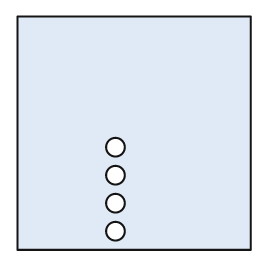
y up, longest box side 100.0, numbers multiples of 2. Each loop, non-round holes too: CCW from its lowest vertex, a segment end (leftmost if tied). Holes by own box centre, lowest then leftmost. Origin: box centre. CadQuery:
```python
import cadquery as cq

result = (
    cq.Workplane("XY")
    .moveTo(-50.0, -50.0)
    .lineTo(50.0, -50.0)
    .lineTo(50.0, 50.0)
    .lineTo(-50.0, 50.0)
    .close()
    .moveTo(-8.0, -42.0)
    .circle(4.0)
    .moveTo(-8.0, -30.0)
    .circle(4.0)
    .moveTo(-8.0, -18.0)
    .circle(4.0)
    .moveTo(-8.0, -6.0)
    .circle(4.0)
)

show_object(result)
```